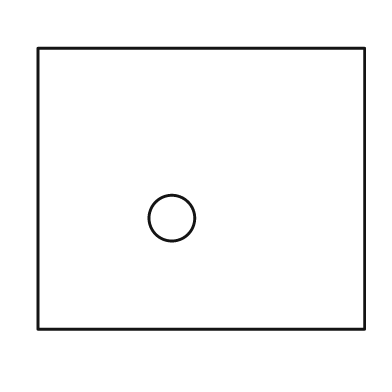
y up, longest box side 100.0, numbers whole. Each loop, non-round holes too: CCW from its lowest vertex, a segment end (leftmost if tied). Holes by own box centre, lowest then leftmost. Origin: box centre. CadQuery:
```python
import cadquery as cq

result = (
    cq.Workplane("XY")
    .moveTo(-50.0, -43.0)
    .lineTo(50.0, -43.0)
    .lineTo(50.0, 43.0)
    .lineTo(-50.0, 43.0)
    .close()
    .moveTo(-9.0, -9.0)
    .circle(7.0)
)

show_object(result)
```